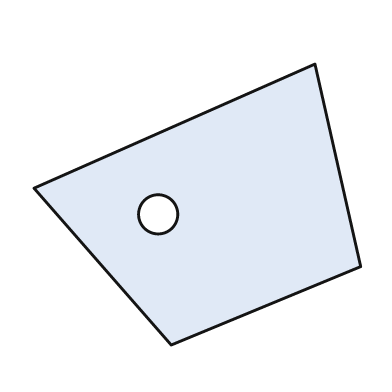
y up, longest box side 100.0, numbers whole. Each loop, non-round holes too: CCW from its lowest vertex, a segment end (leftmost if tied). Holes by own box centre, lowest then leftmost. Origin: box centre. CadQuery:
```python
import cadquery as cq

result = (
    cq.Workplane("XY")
    .moveTo(-8.0, -43.0)
    .lineTo(50.0, -19.0)
    .lineTo(36.0, 43.0)
    .lineTo(-50.0, 5.0)
    .close()
    .moveTo(-12.0, -3.0)
    .circle(6.0)
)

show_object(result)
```